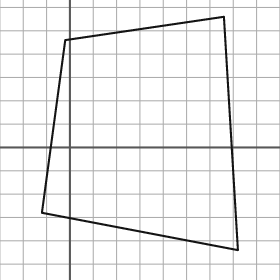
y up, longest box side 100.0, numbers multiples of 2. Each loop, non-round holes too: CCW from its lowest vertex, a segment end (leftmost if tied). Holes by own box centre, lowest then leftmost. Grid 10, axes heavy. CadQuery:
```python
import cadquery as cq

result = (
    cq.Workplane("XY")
    .moveTo(72.0, -44.0)
    .lineTo(66.0, 56.0)
    .lineTo(-2.0, 46.0)
    .lineTo(-12.0, -28.0)
    .close()
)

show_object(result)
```